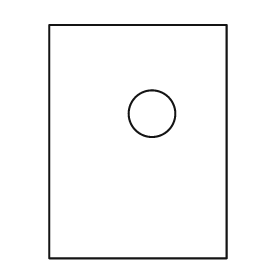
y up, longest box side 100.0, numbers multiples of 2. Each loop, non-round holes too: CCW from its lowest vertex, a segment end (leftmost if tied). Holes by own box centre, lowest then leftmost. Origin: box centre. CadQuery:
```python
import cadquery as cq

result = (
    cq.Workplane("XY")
    .moveTo(-38.0, -50.0)
    .lineTo(38.0, -50.0)
    .lineTo(38.0, 50.0)
    .lineTo(-38.0, 50.0)
    .close()
    .moveTo(6.0, 12.0)
    .circle(10.0)
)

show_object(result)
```